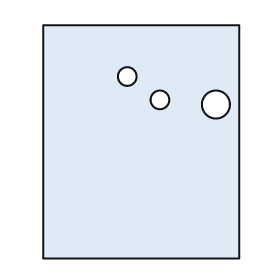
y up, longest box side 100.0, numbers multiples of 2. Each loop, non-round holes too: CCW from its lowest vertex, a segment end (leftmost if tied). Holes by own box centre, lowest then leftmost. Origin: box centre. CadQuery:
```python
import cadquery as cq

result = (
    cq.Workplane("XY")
    .moveTo(-42.0, -50.0)
    .lineTo(42.0, -50.0)
    .lineTo(42.0, 50.0)
    .lineTo(-42.0, 50.0)
    .close()
    .moveTo(32.0, 16.0)
    .circle(6.0)
    .moveTo(8.0, 18.0)
    .circle(4.0)
    .moveTo(-6.0, 28.0)
    .circle(4.0)
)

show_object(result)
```